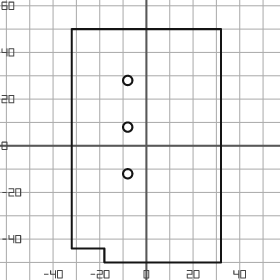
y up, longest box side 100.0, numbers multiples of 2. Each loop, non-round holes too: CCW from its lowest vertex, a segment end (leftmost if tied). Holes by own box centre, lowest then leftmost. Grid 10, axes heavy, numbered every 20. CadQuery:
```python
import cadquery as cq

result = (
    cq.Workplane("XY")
    .moveTo(-18.0, -50.0)
    .lineTo(32.0, -50.0)
    .lineTo(32.0, 50.0)
    .lineTo(-32.0, 50.0)
    .lineTo(-32.0, -44.0)
    .lineTo(-18.0, -44.0)
    .close()
    .moveTo(-8.0, -12.0)
    .circle(2.0)
    .moveTo(-8.0, 8.0)
    .circle(2.0)
    .moveTo(-8.0, 28.0)
    .circle(2.0)
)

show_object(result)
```